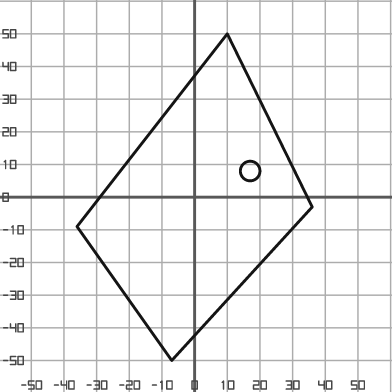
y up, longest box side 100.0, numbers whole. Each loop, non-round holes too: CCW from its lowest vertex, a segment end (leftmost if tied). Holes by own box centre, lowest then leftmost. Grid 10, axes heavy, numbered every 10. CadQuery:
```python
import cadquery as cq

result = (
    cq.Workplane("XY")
    .moveTo(-7.0, -50.0)
    .lineTo(36.0, -3.0)
    .lineTo(10.0, 50.0)
    .lineTo(-36.0, -9.0)
    .close()
    .moveTo(17.0, 8.0)
    .circle(3.0)
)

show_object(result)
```